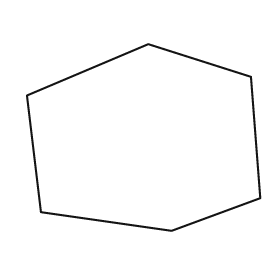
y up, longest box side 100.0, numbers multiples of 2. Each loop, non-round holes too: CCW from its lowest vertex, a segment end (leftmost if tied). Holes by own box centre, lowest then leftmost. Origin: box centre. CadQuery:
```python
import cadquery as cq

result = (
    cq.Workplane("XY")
    .moveTo(12.0, -40.0)
    .lineTo(50.0, -26.0)
    .lineTo(46.0, 26.0)
    .lineTo(2.0, 40.0)
    .lineTo(-50.0, 18.0)
    .lineTo(-44.0, -32.0)
    .close()
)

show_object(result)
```